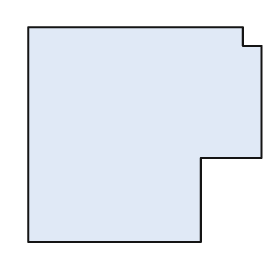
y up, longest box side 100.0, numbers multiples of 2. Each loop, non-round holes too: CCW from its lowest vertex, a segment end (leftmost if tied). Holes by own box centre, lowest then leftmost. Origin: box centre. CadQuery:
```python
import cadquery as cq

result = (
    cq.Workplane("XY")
    .moveTo(-50.0, -46.0)
    .lineTo(24.0, -46.0)
    .lineTo(24.0, -10.0)
    .lineTo(50.0, -10.0)
    .lineTo(50.0, 38.0)
    .lineTo(42.0, 38.0)
    .lineTo(42.0, 46.0)
    .lineTo(-50.0, 46.0)
    .close()
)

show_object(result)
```